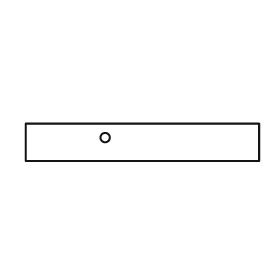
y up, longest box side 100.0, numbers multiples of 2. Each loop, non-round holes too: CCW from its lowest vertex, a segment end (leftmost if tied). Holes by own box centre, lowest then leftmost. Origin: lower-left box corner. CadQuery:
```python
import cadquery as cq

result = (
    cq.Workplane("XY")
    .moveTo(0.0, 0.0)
    .lineTo(100.0, 0.0)
    .lineTo(100.0, 16.0)
    .lineTo(0.0, 16.0)
    .close()
    .moveTo(34.0, 10.0)
    .circle(2.0)
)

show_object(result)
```